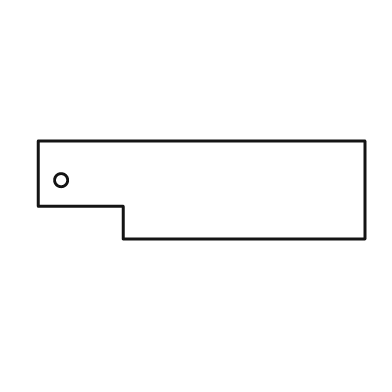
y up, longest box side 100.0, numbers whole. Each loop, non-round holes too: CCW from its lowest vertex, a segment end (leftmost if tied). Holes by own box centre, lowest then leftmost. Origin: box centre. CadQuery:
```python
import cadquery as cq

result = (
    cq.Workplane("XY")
    .moveTo(-24.0, -15.0)
    .lineTo(50.0, -15.0)
    .lineTo(50.0, 15.0)
    .lineTo(-50.0, 15.0)
    .lineTo(-50.0, -5.0)
    .lineTo(-24.0, -5.0)
    .close()
    .moveTo(-43.0, 3.0)
    .circle(2.0)
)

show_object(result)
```